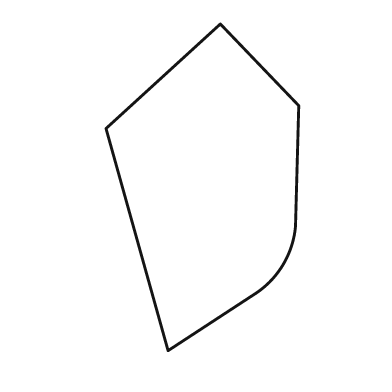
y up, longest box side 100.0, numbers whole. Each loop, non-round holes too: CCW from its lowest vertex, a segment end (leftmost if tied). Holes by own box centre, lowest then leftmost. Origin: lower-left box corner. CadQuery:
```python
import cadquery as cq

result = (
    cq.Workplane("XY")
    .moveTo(19.0, 0.0)
    .lineTo(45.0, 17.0)
    .threePointArc((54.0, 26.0), (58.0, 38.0))
    .lineTo(59.0, 75.0)
    .lineTo(35.0, 100.0)
    .lineTo(0.0, 68.0)
    .close()
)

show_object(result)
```